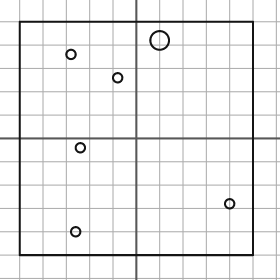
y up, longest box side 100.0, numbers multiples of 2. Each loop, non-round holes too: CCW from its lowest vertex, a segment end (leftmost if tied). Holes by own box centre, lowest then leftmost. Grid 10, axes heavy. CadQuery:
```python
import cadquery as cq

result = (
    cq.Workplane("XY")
    .moveTo(-50.0, -50.0)
    .lineTo(50.0, -50.0)
    .lineTo(50.0, 50.0)
    .lineTo(-50.0, 50.0)
    .close()
    .moveTo(-26.0, -40.0)
    .circle(2.0)
    .moveTo(40.0, -28.0)
    .circle(2.0)
    .moveTo(-24.0, -4.0)
    .circle(2.0)
    .moveTo(-8.0, 26.0)
    .circle(2.0)
    .moveTo(-28.0, 36.0)
    .circle(2.0)
    .moveTo(10.0, 42.0)
    .circle(4.0)
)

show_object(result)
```